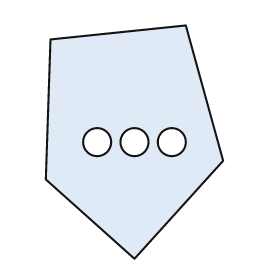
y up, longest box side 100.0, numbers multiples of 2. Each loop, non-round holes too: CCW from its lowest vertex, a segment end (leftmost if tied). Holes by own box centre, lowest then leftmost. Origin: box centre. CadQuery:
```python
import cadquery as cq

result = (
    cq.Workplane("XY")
    .moveTo(0.0, -50.0)
    .lineTo(38.0, -8.0)
    .lineTo(22.0, 50.0)
    .lineTo(-36.0, 44.0)
    .lineTo(-38.0, -16.0)
    .close()
    .moveTo(-16.0, 0.0)
    .circle(6.0)
    .moveTo(0.0, 0.0)
    .circle(6.0)
    .moveTo(16.0, 0.0)
    .circle(6.0)
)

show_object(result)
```